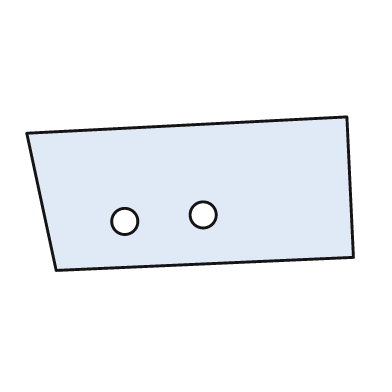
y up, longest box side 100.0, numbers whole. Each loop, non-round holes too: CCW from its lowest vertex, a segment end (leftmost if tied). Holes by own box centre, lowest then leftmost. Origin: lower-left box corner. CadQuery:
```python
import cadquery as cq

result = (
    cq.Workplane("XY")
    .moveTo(9.0, 0.0)
    .lineTo(100.0, 4.0)
    .lineTo(98.0, 47.0)
    .lineTo(0.0, 42.0)
    .close()
    .moveTo(30.0, 15.0)
    .circle(4.0)
    .moveTo(54.0, 17.0)
    .circle(4.0)
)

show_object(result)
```